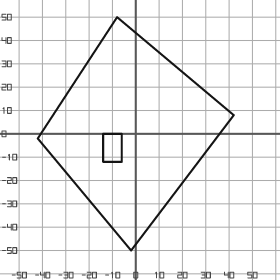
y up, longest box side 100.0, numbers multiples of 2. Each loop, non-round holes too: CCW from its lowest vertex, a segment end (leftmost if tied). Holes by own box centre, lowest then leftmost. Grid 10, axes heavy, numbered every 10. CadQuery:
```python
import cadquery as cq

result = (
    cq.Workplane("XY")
    .moveTo(-2.0, -50.0)
    .lineTo(42.0, 8.0)
    .lineTo(-8.0, 50.0)
    .lineTo(-42.0, -2.0)
    .close()
    .moveTo(-14.0, -12.0)
    .lineTo(-6.0, -12.0)
    .lineTo(-6.0, 0.0)
    .lineTo(-14.0, 0.0)
    .close()
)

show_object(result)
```